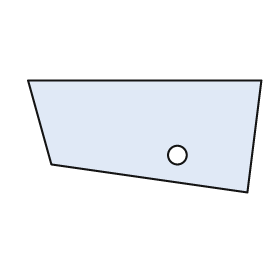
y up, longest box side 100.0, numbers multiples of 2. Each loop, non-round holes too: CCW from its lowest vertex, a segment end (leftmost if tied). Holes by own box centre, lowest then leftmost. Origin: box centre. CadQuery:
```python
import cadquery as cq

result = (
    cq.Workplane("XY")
    .moveTo(44.0, -24.0)
    .lineTo(50.0, 24.0)
    .lineTo(-50.0, 24.0)
    .lineTo(-40.0, -12.0)
    .close()
    .moveTo(14.0, -8.0)
    .circle(4.0)
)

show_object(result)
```